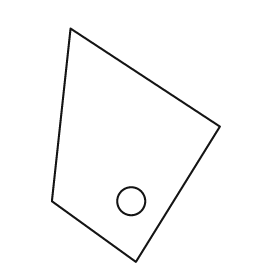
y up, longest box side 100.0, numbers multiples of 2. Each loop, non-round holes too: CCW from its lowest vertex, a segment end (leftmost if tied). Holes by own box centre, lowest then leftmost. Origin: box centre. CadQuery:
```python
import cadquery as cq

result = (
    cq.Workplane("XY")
    .moveTo(0.0, -50.0)
    .lineTo(36.0, 8.0)
    .lineTo(-28.0, 50.0)
    .lineTo(-36.0, -24.0)
    .close()
    .moveTo(-2.0, -24.0)
    .circle(6.0)
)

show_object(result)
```